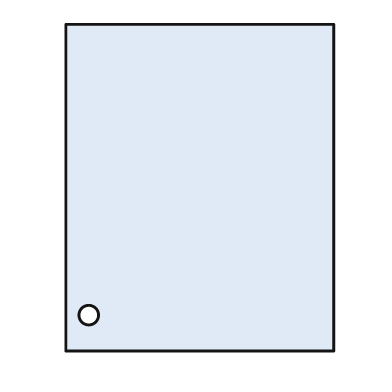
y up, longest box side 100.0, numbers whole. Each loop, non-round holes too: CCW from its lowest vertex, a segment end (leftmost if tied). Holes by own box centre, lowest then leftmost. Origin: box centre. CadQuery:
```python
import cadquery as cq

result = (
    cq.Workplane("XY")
    .moveTo(-41.0, -50.0)
    .lineTo(41.0, -50.0)
    .lineTo(41.0, 50.0)
    .lineTo(-41.0, 50.0)
    .close()
    .moveTo(-34.0, -39.0)
    .circle(3.0)
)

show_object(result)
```